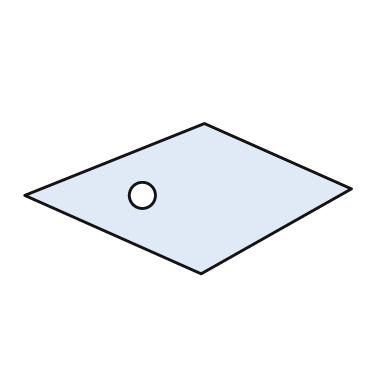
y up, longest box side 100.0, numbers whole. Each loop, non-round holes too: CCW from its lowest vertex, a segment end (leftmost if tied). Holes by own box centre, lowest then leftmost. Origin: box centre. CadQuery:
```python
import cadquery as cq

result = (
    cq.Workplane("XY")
    .moveTo(4.0, -23.0)
    .lineTo(50.0, 3.0)
    .lineTo(5.0, 23.0)
    .lineTo(-50.0, 1.0)
    .close()
    .moveTo(-14.0, 1.0)
    .circle(4.0)
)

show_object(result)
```